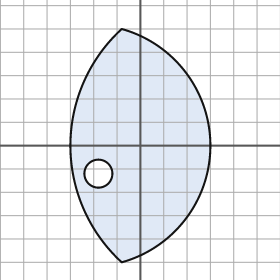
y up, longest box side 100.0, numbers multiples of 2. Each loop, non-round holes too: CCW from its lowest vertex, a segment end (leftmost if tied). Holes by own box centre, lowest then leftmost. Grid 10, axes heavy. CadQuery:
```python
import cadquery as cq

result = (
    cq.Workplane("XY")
    .moveTo(-8.0, -50.0)
    .threePointArc((30.0, 0.0), (-8.0, 50.0))
    .threePointArc((-30.0, 0.0), (-8.0, -50.0))
    .close()
    .moveTo(-18.0, -12.0)
    .circle(6.0)
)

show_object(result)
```